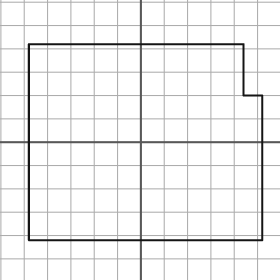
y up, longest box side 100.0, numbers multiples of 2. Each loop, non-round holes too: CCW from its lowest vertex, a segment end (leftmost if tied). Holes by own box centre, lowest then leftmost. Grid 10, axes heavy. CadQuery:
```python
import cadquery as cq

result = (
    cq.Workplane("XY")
    .moveTo(-48.0, -42.0)
    .lineTo(52.0, -42.0)
    .lineTo(52.0, 20.0)
    .lineTo(44.0, 20.0)
    .lineTo(44.0, 42.0)
    .lineTo(-48.0, 42.0)
    .close()
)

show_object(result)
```